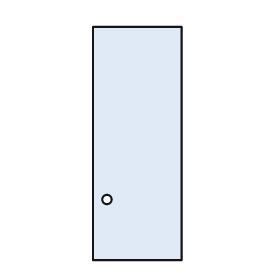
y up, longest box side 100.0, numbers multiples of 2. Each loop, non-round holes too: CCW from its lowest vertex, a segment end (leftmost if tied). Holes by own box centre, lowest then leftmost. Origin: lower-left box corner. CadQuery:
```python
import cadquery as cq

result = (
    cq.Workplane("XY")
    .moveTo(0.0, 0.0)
    .lineTo(38.0, 0.0)
    .lineTo(38.0, 100.0)
    .lineTo(0.0, 100.0)
    .close()
    .moveTo(6.0, 26.0)
    .circle(2.0)
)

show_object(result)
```